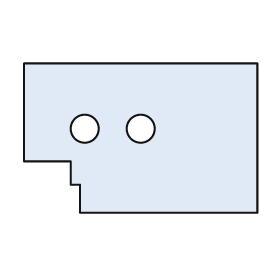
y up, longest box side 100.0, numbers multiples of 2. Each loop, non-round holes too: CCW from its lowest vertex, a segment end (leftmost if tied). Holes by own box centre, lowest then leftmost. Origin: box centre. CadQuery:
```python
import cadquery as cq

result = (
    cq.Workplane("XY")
    .moveTo(-26.0, -32.0)
    .lineTo(50.0, -32.0)
    .lineTo(50.0, 32.0)
    .lineTo(-50.0, 32.0)
    .lineTo(-50.0, -10.0)
    .lineTo(-30.0, -10.0)
    .lineTo(-30.0, -20.0)
    .lineTo(-26.0, -20.0)
    .close()
    .moveTo(-24.0, 4.0)
    .circle(6.0)
    .moveTo(0.0, 4.0)
    .circle(6.0)
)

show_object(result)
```